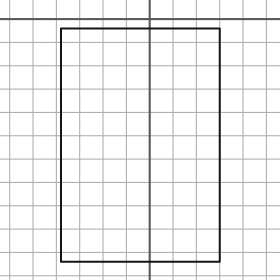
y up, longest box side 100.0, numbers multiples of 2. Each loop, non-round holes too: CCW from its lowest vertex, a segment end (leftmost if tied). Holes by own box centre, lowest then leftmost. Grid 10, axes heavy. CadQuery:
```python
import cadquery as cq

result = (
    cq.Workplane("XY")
    .moveTo(-38.0, -104.0)
    .lineTo(30.0, -104.0)
    .lineTo(30.0, -4.0)
    .lineTo(-38.0, -4.0)
    .close()
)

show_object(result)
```